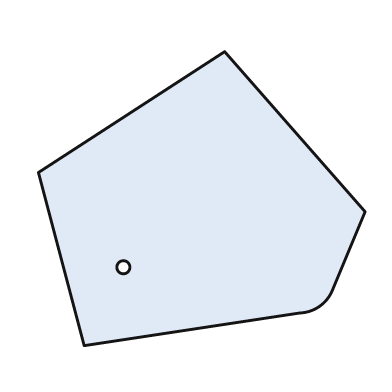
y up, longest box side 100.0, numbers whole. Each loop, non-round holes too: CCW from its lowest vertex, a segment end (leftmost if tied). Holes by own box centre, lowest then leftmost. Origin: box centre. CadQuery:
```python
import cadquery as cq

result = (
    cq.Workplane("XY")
    .moveTo(-36.0, -45.0)
    .lineTo(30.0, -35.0)
    .threePointArc((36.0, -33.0), (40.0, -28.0))
    .lineTo(50.0, -4.0)
    .lineTo(7.0, 45.0)
    .lineTo(-50.0, 8.0)
    .close()
    .moveTo(-24.0, -21.0)
    .circle(2.0)
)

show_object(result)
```